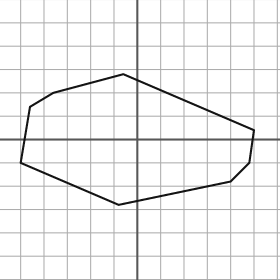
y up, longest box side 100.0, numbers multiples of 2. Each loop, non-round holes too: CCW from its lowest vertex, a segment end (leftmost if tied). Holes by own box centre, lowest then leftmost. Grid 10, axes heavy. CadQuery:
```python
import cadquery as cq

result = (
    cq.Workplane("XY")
    .moveTo(-8.0, -28.0)
    .lineTo(40.0, -18.0)
    .lineTo(48.0, -10.0)
    .lineTo(50.0, 4.0)
    .lineTo(-6.0, 28.0)
    .lineTo(-36.0, 20.0)
    .lineTo(-46.0, 14.0)
    .lineTo(-50.0, -10.0)
    .close()
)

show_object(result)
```